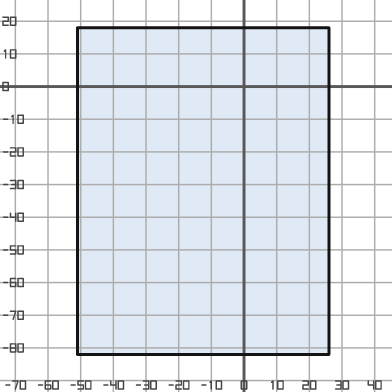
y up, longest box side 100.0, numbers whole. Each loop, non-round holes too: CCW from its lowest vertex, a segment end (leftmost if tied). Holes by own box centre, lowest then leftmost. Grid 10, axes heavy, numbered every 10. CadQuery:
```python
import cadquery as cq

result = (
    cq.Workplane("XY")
    .moveTo(-51.0, -82.0)
    .lineTo(26.0, -82.0)
    .lineTo(26.0, 18.0)
    .lineTo(-51.0, 18.0)
    .close()
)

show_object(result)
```